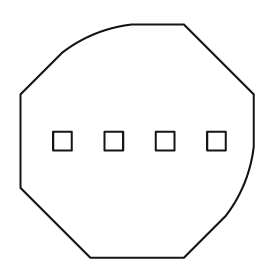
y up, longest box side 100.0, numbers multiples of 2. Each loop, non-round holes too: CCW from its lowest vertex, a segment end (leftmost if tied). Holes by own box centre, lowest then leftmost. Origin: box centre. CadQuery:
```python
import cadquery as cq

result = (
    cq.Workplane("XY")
    .moveTo(-20.0, -50.0)
    .lineTo(20.0, -50.0)
    .lineTo(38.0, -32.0)
    .threePointArc((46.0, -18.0), (50.0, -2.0))
    .lineTo(50.0, 20.0)
    .lineTo(20.0, 50.0)
    .lineTo(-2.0, 50.0)
    .threePointArc((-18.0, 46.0), (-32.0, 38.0))
    .lineTo(-50.0, 20.0)
    .lineTo(-50.0, -20.0)
    .close()
    .moveTo(-36.0, -4.0)
    .lineTo(-28.0, -4.0)
    .lineTo(-28.0, 4.0)
    .lineTo(-36.0, 4.0)
    .close()
    .moveTo(-14.0, -4.0)
    .lineTo(-6.0, -4.0)
    .lineTo(-6.0, 4.0)
    .lineTo(-14.0, 4.0)
    .close()
    .moveTo(8.0, -4.0)
    .lineTo(16.0, -4.0)
    .lineTo(16.0, 4.0)
    .lineTo(8.0, 4.0)
    .close()
    .moveTo(30.0, -4.0)
    .lineTo(38.0, -4.0)
    .lineTo(38.0, 4.0)
    .lineTo(30.0, 4.0)
    .close()
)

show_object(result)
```